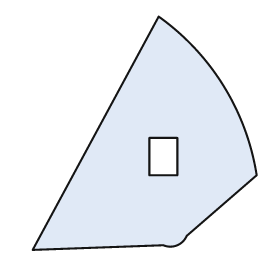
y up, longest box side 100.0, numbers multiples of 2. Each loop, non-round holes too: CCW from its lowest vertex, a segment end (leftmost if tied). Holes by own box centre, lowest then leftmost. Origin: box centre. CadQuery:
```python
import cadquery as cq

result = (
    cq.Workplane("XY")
    .moveTo(-48.0, -50.0)
    .lineTo(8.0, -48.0)
    .threePointArc((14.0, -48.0), (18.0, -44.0))
    .lineTo(48.0, -18.0)
    .threePointArc((34.0, 20.0), (6.0, 50.0))
    .close()
    .moveTo(2.0, -18.0)
    .lineTo(14.0, -18.0)
    .lineTo(14.0, -2.0)
    .lineTo(2.0, -2.0)
    .close()
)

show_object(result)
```